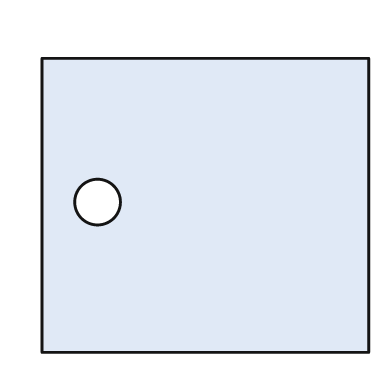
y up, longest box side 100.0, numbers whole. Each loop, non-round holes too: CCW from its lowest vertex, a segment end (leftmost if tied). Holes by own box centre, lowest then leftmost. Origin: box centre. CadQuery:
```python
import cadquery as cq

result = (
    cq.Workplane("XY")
    .moveTo(-50.0, -45.0)
    .lineTo(50.0, -45.0)
    .lineTo(50.0, 45.0)
    .lineTo(-50.0, 45.0)
    .close()
    .moveTo(-33.0, 1.0)
    .circle(7.0)
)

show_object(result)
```